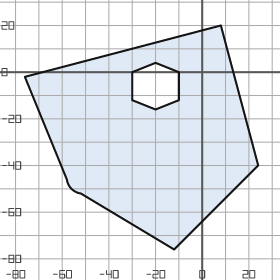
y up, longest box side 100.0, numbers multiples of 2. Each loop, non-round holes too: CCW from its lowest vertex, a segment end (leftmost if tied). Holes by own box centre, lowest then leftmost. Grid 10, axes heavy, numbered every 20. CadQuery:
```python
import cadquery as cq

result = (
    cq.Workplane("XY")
    .moveTo(-12.0, -76.0)
    .lineTo(24.0, -40.0)
    .lineTo(8.0, 20.0)
    .lineTo(-76.0, -2.0)
    .lineTo(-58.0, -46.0)
    .threePointArc((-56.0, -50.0), (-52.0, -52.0))
    .close()
    .moveTo(-20.0, -16.0)
    .lineTo(-10.0, -12.0)
    .lineTo(-10.0, 0.0)
    .lineTo(-20.0, 4.0)
    .lineTo(-30.0, 0.0)
    .lineTo(-30.0, -12.0)
    .close()
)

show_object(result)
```